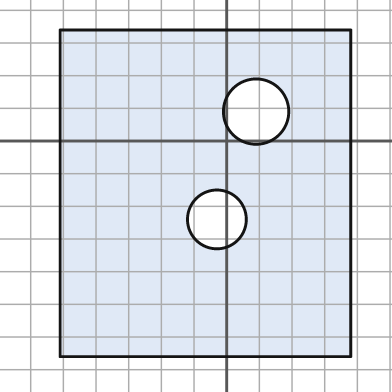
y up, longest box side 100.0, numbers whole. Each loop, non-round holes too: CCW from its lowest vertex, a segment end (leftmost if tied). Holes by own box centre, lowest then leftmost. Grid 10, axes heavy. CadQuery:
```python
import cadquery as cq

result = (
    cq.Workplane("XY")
    .moveTo(-51.0, -66.0)
    .lineTo(38.0, -66.0)
    .lineTo(38.0, 34.0)
    .lineTo(-51.0, 34.0)
    .close()
    .moveTo(-3.0, -24.0)
    .circle(9.0)
    .moveTo(9.0, 9.0)
    .circle(10.0)
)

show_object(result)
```